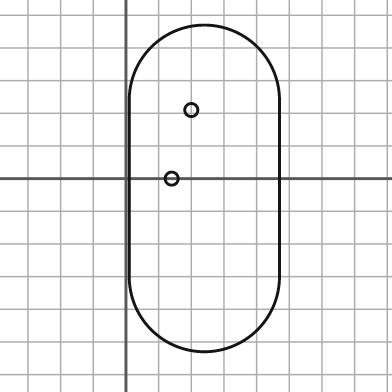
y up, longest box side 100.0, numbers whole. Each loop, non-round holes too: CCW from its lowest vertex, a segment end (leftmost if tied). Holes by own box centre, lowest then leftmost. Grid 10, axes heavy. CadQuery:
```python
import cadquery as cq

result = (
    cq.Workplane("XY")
    .moveTo(1.0, -30.0)
    .threePointArc((24.0, -53.0), (47.0, -30.0))
    .lineTo(47.0, 24.0)
    .threePointArc((24.0, 47.0), (1.0, 24.0))
    .close()
    .moveTo(14.0, 0.0)
    .circle(2.0)
    .moveTo(20.0, 21.0)
    .circle(2.0)
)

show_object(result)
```